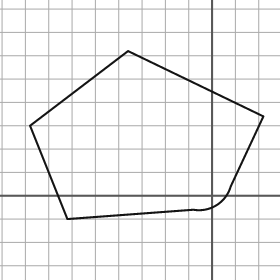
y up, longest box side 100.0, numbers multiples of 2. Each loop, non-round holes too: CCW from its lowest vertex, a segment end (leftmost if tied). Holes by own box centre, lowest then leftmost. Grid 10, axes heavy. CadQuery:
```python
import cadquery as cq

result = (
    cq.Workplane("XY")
    .moveTo(-62.0, -10.0)
    .lineTo(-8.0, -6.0)
    .threePointArc((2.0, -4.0), (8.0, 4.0))
    .lineTo(22.0, 34.0)
    .lineTo(-36.0, 62.0)
    .lineTo(-78.0, 30.0)
    .close()
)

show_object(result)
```